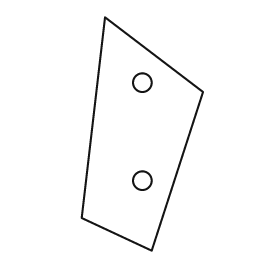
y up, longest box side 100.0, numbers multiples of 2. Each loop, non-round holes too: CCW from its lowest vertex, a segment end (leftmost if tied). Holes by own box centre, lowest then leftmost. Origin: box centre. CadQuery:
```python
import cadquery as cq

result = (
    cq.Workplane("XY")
    .moveTo(4.0, -50.0)
    .lineTo(26.0, 18.0)
    .lineTo(-16.0, 50.0)
    .lineTo(-26.0, -36.0)
    .close()
    .moveTo(0.0, -20.0)
    .circle(4.0)
    .moveTo(0.0, 22.0)
    .circle(4.0)
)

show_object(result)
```